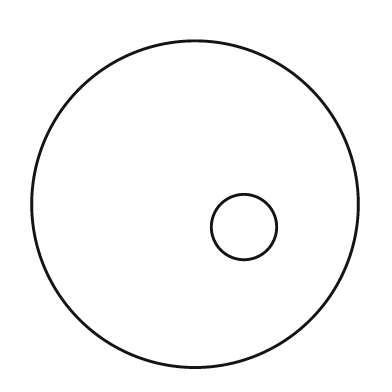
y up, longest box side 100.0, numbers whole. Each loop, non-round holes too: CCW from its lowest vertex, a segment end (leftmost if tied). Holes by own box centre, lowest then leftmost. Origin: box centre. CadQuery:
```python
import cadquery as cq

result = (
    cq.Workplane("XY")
    .moveTo(0.0, 0.0)
    .circle(50.0)
    .moveTo(15.0, -7.0)
    .circle(10.0)
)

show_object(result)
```